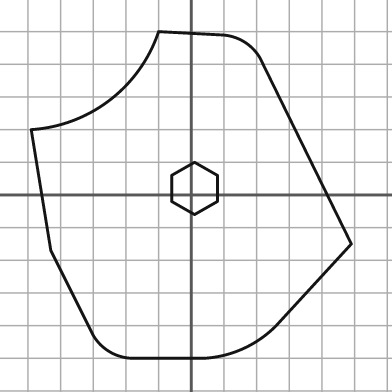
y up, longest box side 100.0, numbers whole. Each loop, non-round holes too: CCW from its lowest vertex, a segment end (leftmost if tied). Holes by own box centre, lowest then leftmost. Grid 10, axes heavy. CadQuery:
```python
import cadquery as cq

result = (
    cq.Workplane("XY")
    .moveTo(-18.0, -50.0)
    .lineTo(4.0, -50.0)
    .threePointArc((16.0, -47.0), (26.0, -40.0))
    .lineTo(49.0, -15.0)
    .lineTo(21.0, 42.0)
    .threePointArc((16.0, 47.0), (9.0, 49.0))
    .lineTo(-10.0, 50.0)
    .threePointArc((-25.0, 29.0), (-49.0, 20.0))
    .lineTo(-43.0, -17.0)
    .lineTo(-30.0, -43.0)
    .threePointArc((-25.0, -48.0), (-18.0, -50.0))
    .close()
    .moveTo(1.0, -6.0)
    .lineTo(8.0, -2.0)
    .lineTo(8.0, 6.0)
    .lineTo(1.0, 10.0)
    .lineTo(-6.0, 6.0)
    .lineTo(-6.0, -2.0)
    .close()
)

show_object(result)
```